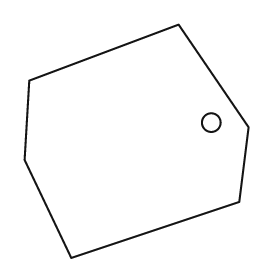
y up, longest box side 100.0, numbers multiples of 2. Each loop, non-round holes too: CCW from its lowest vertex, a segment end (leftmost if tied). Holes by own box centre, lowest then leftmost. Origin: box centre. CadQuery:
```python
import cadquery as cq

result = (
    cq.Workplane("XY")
    .moveTo(-28.0, -50.0)
    .lineTo(44.0, -26.0)
    .lineTo(48.0, 6.0)
    .lineTo(18.0, 50.0)
    .lineTo(-46.0, 26.0)
    .lineTo(-48.0, -8.0)
    .close()
    .moveTo(32.0, 8.0)
    .circle(4.0)
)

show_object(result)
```